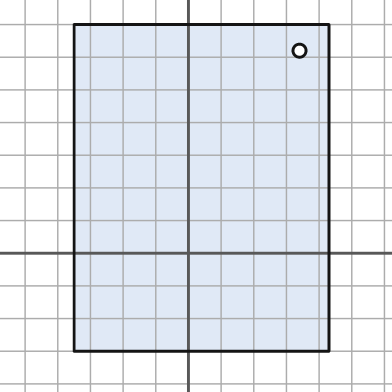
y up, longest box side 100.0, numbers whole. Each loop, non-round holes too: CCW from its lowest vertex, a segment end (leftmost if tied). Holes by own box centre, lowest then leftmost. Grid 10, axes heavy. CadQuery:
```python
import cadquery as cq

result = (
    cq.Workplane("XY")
    .moveTo(-35.0, -30.0)
    .lineTo(43.0, -30.0)
    .lineTo(43.0, 70.0)
    .lineTo(-35.0, 70.0)
    .close()
    .moveTo(34.0, 62.0)
    .circle(2.0)
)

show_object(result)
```